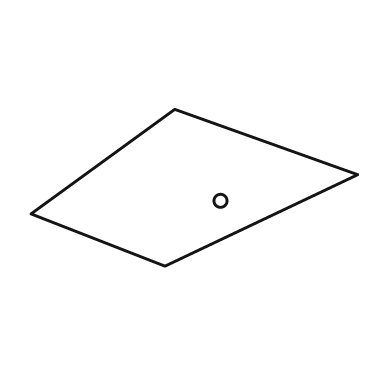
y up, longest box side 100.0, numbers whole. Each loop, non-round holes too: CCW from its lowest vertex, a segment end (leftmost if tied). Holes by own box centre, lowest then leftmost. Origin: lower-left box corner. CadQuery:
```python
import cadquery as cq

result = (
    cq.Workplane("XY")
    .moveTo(41.0, 0.0)
    .lineTo(100.0, 28.0)
    .lineTo(44.0, 48.0)
    .lineTo(0.0, 16.0)
    .close()
    .moveTo(58.0, 20.0)
    .circle(2.0)
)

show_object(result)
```